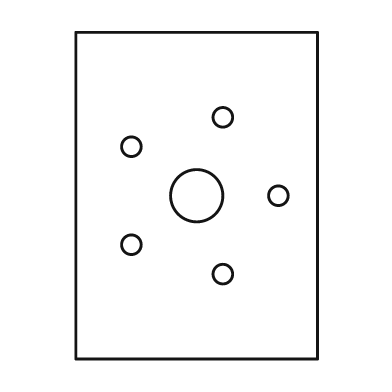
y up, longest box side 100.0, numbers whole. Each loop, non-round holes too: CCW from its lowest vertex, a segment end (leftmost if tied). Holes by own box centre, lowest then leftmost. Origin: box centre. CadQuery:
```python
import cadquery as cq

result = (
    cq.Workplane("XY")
    .moveTo(-37.0, -50.0)
    .lineTo(37.0, -50.0)
    .lineTo(37.0, 50.0)
    .lineTo(-37.0, 50.0)
    .close()
    .moveTo(8.0, -24.0)
    .circle(3.0)
    .moveTo(-20.0, -15.0)
    .circle(3.0)
    .moveTo(0.0, 0.0)
    .circle(8.0)
    .moveTo(25.0, 0.0)
    .circle(3.0)
    .moveTo(-20.0, 15.0)
    .circle(3.0)
    .moveTo(8.0, 24.0)
    .circle(3.0)
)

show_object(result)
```